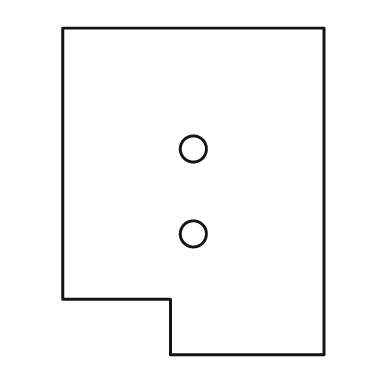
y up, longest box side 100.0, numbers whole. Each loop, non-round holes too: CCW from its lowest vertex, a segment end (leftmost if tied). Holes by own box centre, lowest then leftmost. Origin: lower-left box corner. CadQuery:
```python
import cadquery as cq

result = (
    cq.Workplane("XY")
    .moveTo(33.0, 0.0)
    .lineTo(80.0, 0.0)
    .lineTo(80.0, 100.0)
    .lineTo(0.0, 100.0)
    .lineTo(0.0, 17.0)
    .lineTo(33.0, 17.0)
    .close()
    .moveTo(40.0, 37.0)
    .circle(4.0)
    .moveTo(40.0, 63.0)
    .circle(4.0)
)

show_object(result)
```